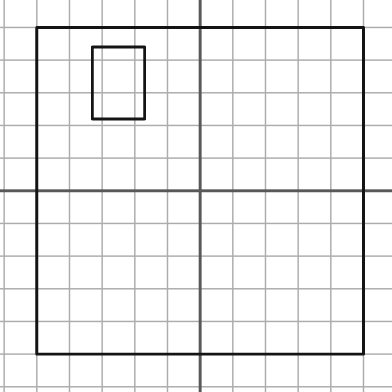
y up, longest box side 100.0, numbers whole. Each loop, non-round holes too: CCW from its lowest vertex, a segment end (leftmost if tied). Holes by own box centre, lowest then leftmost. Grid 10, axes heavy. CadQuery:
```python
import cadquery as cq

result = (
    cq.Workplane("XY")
    .moveTo(-50.0, -50.0)
    .lineTo(50.0, -50.0)
    .lineTo(50.0, 50.0)
    .lineTo(-50.0, 50.0)
    .close()
    .moveTo(-33.0, 22.0)
    .lineTo(-17.0, 22.0)
    .lineTo(-17.0, 44.0)
    .lineTo(-33.0, 44.0)
    .close()
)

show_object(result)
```